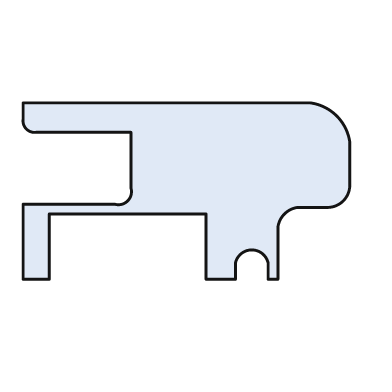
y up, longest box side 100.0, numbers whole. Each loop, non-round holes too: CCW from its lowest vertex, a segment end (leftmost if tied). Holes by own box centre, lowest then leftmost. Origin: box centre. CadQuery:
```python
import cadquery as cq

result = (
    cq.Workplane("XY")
    .moveTo(-50.0, -27.0)
    .lineTo(-42.0, -27.0)
    .lineTo(-42.0, -7.0)
    .lineTo(6.0, -7.0)
    .lineTo(6.0, -27.0)
    .lineTo(15.0, -27.0)
    .lineTo(15.0, -22.0)
    .threePointArc((20.0, -18.0), (25.0, -22.0))
    .lineTo(25.0, -27.0)
    .lineTo(28.0, -27.0)
    .lineTo(28.0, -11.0)
    .threePointArc((30.0, -7.0), (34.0, -5.0))
    .lineTo(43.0, -5.0)
    .threePointArc((48.0, -3.0), (50.0, 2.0))
    .lineTo(50.0, 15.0)
    .threePointArc((46.0, 23.0), (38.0, 27.0))
    .lineTo(-50.0, 27.0)
    .lineTo(-50.0, 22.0)
    .threePointArc((-49.0, 19.0), (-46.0, 18.0))
    .lineTo(-17.0, 18.0)
    .lineTo(-17.0, 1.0)
    .threePointArc((-18.0, -3.0), (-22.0, -4.0))
    .lineTo(-50.0, -4.0)
    .close()
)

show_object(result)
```